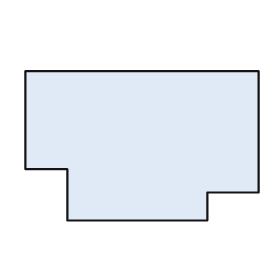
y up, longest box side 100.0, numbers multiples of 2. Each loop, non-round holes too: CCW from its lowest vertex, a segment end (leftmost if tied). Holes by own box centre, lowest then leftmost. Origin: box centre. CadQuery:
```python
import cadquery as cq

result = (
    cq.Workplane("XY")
    .moveTo(-32.0, -32.0)
    .lineTo(28.0, -32.0)
    .lineTo(28.0, -20.0)
    .lineTo(50.0, -20.0)
    .lineTo(50.0, 32.0)
    .lineTo(-50.0, 32.0)
    .lineTo(-50.0, -10.0)
    .lineTo(-32.0, -10.0)
    .close()
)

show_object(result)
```